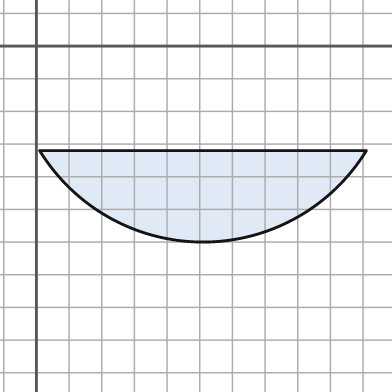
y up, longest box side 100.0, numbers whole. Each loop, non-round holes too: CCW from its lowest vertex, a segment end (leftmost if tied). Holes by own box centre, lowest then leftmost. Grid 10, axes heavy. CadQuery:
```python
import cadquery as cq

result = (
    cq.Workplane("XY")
    .moveTo(1.0, -32.0)
    .threePointArc((51.0, -60.0), (101.0, -32.0))
    .close()
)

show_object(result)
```